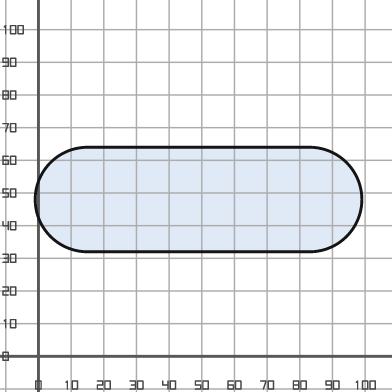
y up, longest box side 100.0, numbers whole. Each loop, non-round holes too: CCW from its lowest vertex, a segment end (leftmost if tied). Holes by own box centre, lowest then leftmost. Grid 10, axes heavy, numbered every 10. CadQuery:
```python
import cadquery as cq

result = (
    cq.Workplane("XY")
    .moveTo(15.0, 32.0)
    .lineTo(83.0, 32.0)
    .threePointArc((99.0, 48.0), (83.0, 64.0))
    .lineTo(15.0, 64.0)
    .threePointArc((-1.0, 48.0), (15.0, 32.0))
    .close()
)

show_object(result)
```